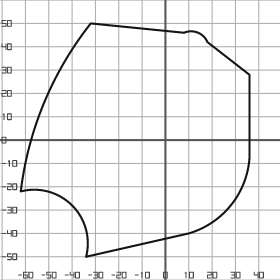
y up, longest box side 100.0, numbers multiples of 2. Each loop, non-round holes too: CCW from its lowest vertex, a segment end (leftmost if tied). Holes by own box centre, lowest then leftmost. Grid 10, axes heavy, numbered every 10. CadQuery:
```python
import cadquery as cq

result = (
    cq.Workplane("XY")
    .moveTo(-34.0, -50.0)
    .lineTo(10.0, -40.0)
    .threePointArc((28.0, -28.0), (36.0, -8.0))
    .lineTo(36.0, 28.0)
    .lineTo(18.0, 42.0)
    .threePointArc((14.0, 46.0), (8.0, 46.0))
    .lineTo(-32.0, 50.0)
    .threePointArc((-52.0, 16.0), (-62.0, -22.0))
    .threePointArc((-40.0, -28.0), (-34.0, -50.0))
    .close()
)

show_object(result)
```